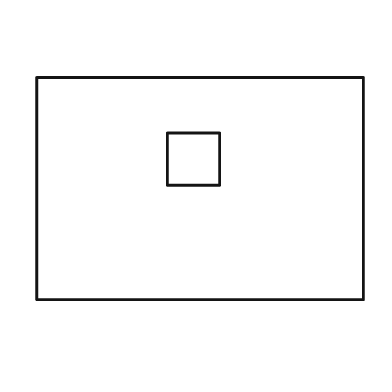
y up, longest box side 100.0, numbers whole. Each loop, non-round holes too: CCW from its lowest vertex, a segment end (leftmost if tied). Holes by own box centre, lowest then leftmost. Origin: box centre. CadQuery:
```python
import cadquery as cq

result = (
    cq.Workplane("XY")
    .moveTo(-50.0, -34.0)
    .lineTo(50.0, -34.0)
    .lineTo(50.0, 34.0)
    .lineTo(-50.0, 34.0)
    .close()
    .moveTo(-10.0, 1.0)
    .lineTo(6.0, 1.0)
    .lineTo(6.0, 17.0)
    .lineTo(-10.0, 17.0)
    .close()
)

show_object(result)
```